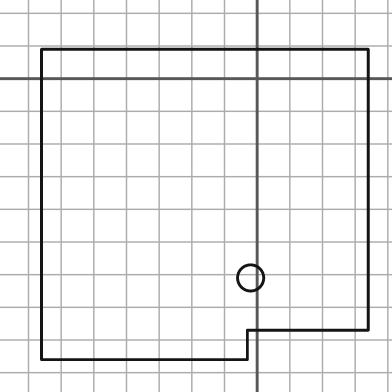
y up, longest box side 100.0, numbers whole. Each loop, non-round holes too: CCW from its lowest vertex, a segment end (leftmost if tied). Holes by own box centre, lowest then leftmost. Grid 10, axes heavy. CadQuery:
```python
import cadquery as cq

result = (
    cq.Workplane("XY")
    .moveTo(-66.0, -86.0)
    .lineTo(-3.0, -86.0)
    .lineTo(-3.0, -77.0)
    .lineTo(34.0, -77.0)
    .lineTo(34.0, 9.0)
    .lineTo(-66.0, 9.0)
    .close()
    .moveTo(-2.0, -61.0)
    .circle(4.0)
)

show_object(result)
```